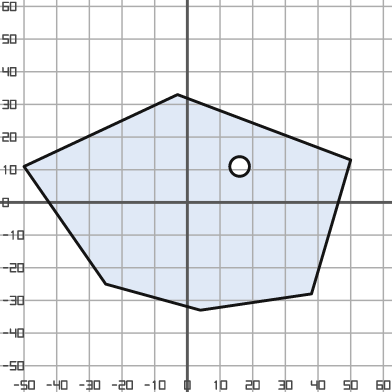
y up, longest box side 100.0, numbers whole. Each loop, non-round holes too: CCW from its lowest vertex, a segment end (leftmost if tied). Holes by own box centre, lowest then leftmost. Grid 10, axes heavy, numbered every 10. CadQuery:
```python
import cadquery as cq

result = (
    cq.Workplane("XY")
    .moveTo(4.0, -33.0)
    .lineTo(38.0, -28.0)
    .lineTo(50.0, 13.0)
    .lineTo(-3.0, 33.0)
    .lineTo(-50.0, 11.0)
    .lineTo(-25.0, -25.0)
    .close()
    .moveTo(16.0, 11.0)
    .circle(3.0)
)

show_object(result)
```